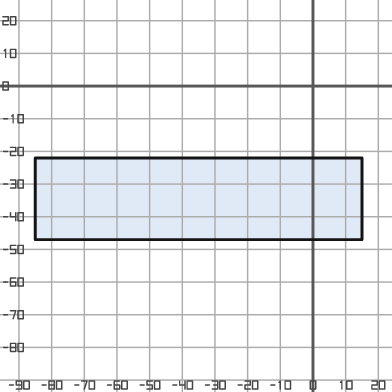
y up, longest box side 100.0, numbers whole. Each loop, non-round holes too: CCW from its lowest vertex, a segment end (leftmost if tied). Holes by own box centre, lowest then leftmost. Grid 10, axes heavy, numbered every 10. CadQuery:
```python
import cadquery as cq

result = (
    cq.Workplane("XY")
    .moveTo(-85.0, -47.0)
    .lineTo(15.0, -47.0)
    .lineTo(15.0, -22.0)
    .lineTo(-85.0, -22.0)
    .close()
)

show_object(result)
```